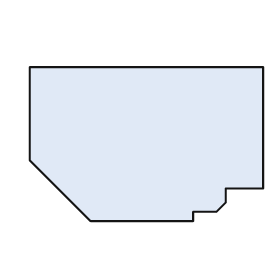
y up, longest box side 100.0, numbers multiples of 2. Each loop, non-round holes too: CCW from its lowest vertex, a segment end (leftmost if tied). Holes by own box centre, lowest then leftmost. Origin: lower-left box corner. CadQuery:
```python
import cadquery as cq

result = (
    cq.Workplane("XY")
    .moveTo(26.0, 0.0)
    .lineTo(70.0, 0.0)
    .lineTo(70.0, 4.0)
    .lineTo(80.0, 4.0)
    .lineTo(84.0, 8.0)
    .lineTo(84.0, 14.0)
    .lineTo(100.0, 14.0)
    .lineTo(100.0, 66.0)
    .lineTo(0.0, 66.0)
    .lineTo(0.0, 26.0)
    .close()
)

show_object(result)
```